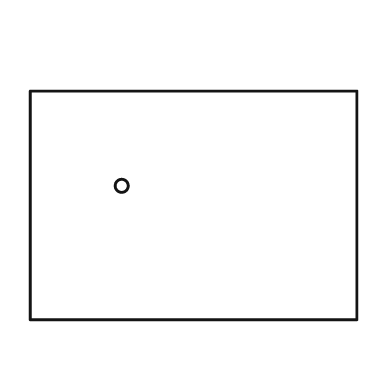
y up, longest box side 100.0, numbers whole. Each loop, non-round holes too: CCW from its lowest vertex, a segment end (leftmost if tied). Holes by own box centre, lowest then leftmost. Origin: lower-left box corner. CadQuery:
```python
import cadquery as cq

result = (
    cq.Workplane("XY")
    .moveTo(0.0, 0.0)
    .lineTo(100.0, 0.0)
    .lineTo(100.0, 70.0)
    .lineTo(0.0, 70.0)
    .close()
    .moveTo(28.0, 41.0)
    .circle(2.0)
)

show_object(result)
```